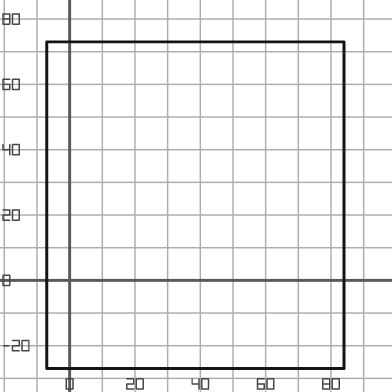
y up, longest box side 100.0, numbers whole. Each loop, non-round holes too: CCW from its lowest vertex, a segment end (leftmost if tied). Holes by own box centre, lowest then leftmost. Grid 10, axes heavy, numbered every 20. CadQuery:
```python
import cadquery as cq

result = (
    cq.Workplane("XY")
    .moveTo(-7.0, -27.0)
    .lineTo(84.0, -27.0)
    .lineTo(84.0, 73.0)
    .lineTo(-7.0, 73.0)
    .close()
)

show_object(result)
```